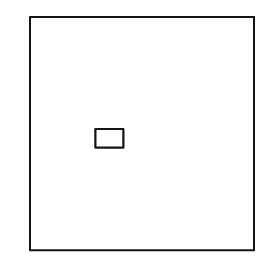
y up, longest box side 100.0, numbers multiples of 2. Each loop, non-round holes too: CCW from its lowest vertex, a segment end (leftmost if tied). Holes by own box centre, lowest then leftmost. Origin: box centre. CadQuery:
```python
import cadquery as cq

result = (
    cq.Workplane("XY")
    .moveTo(-48.0, -50.0)
    .lineTo(48.0, -50.0)
    .lineTo(48.0, 50.0)
    .lineTo(-48.0, 50.0)
    .close()
    .moveTo(-20.0, -6.0)
    .lineTo(-8.0, -6.0)
    .lineTo(-8.0, 2.0)
    .lineTo(-20.0, 2.0)
    .close()
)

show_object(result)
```